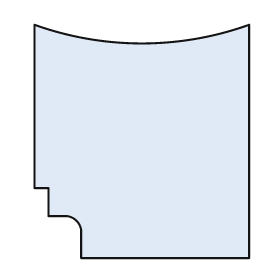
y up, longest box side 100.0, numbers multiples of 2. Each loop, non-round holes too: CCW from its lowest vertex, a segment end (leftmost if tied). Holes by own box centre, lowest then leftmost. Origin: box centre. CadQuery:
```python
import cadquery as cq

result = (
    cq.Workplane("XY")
    .moveTo(-26.0, -50.0)
    .lineTo(46.0, -50.0)
    .lineTo(46.0, 50.0)
    .threePointArc((0.0, 42.0), (-46.0, 50.0))
    .lineTo(-46.0, -20.0)
    .lineTo(-40.0, -20.0)
    .lineTo(-40.0, -32.0)
    .lineTo(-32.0, -32.0)
    .threePointArc((-28.0, -34.0), (-26.0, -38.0))
    .close()
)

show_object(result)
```